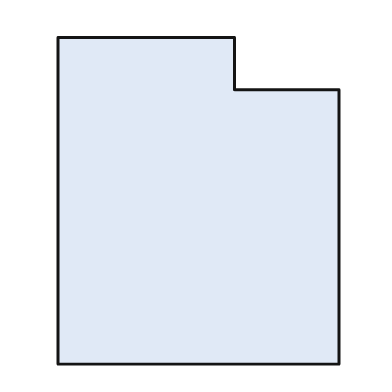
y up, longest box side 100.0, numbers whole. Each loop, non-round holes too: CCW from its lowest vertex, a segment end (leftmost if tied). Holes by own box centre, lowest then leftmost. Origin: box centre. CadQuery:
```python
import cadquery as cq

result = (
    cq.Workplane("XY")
    .moveTo(-43.0, -50.0)
    .lineTo(43.0, -50.0)
    .lineTo(43.0, 34.0)
    .lineTo(11.0, 34.0)
    .lineTo(11.0, 50.0)
    .lineTo(-43.0, 50.0)
    .close()
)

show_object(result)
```